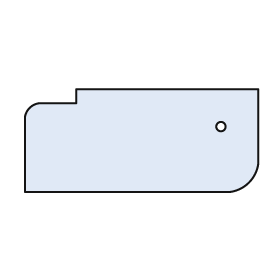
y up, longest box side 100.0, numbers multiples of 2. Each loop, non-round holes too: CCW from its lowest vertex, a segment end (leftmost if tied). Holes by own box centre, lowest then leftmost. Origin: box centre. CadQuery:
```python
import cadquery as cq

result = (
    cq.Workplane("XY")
    .moveTo(-50.0, -22.0)
    .lineTo(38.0, -22.0)
    .threePointArc((46.0, -18.0), (50.0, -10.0))
    .lineTo(50.0, 22.0)
    .lineTo(-28.0, 22.0)
    .lineTo(-28.0, 16.0)
    .lineTo(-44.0, 16.0)
    .threePointArc((-48.0, 14.0), (-50.0, 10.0))
    .close()
    .moveTo(34.0, 6.0)
    .circle(2.0)
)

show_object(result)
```